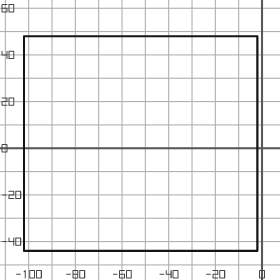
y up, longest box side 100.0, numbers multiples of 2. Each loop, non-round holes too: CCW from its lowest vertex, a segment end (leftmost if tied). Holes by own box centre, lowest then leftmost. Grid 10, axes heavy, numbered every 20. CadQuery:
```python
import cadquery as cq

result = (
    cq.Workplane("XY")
    .moveTo(-102.0, -44.0)
    .lineTo(-2.0, -44.0)
    .lineTo(-2.0, 48.0)
    .lineTo(-102.0, 48.0)
    .close()
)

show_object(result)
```